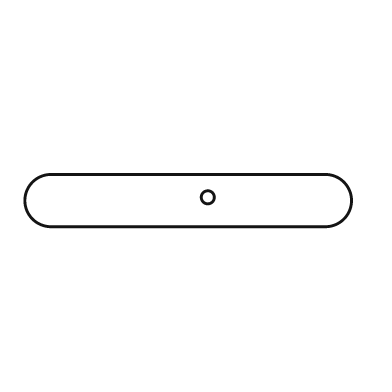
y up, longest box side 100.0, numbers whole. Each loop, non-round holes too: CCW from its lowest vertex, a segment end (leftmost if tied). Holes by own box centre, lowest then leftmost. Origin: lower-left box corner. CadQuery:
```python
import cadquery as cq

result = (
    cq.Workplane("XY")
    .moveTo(8.0, 0.0)
    .lineTo(92.0, 0.0)
    .threePointArc((100.0, 8.0), (92.0, 16.0))
    .lineTo(8.0, 16.0)
    .threePointArc((0.0, 8.0), (8.0, 0.0))
    .close()
    .moveTo(56.0, 9.0)
    .circle(2.0)
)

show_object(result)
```